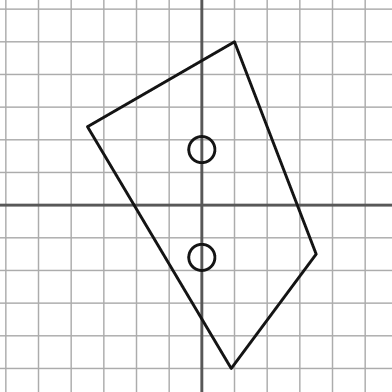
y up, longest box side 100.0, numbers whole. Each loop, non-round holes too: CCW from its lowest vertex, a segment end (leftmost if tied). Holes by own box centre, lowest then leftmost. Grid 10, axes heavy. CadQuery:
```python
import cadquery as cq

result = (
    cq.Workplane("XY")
    .moveTo(9.0, -50.0)
    .lineTo(35.0, -15.0)
    .lineTo(10.0, 50.0)
    .lineTo(-35.0, 24.0)
    .close()
    .moveTo(0.0, -16.0)
    .circle(4.0)
    .moveTo(0.0, 17.0)
    .circle(4.0)
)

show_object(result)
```